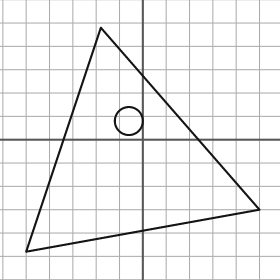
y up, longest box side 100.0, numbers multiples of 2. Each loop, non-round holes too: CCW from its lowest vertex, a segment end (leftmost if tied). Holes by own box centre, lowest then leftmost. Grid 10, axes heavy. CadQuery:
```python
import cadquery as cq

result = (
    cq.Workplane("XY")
    .moveTo(-50.0, -48.0)
    .lineTo(50.0, -30.0)
    .lineTo(-18.0, 48.0)
    .close()
    .moveTo(-6.0, 8.0)
    .circle(6.0)
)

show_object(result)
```